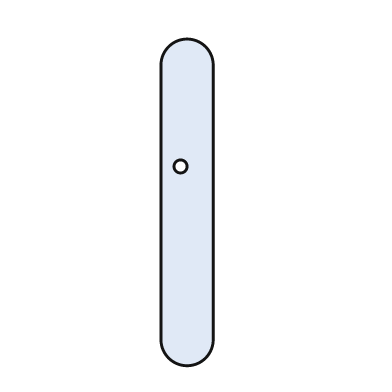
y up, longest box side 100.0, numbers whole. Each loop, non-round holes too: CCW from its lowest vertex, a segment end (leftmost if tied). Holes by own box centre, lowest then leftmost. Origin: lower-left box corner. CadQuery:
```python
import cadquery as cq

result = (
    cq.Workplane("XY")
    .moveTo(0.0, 8.0)
    .threePointArc((8.0, 0.0), (16.0, 8.0))
    .lineTo(16.0, 92.0)
    .threePointArc((8.0, 100.0), (0.0, 92.0))
    .close()
    .moveTo(6.0, 61.0)
    .circle(2.0)
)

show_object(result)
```